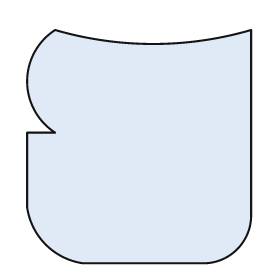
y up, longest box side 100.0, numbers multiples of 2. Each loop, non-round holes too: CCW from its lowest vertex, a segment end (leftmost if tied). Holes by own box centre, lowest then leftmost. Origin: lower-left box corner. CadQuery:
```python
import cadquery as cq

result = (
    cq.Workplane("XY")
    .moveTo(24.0, 0.0)
    .lineTo(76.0, 0.0)
    .threePointArc((90.0, 6.0), (96.0, 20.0))
    .lineTo(96.0, 100.0)
    .threePointArc((54.0, 94.0), (12.0, 100.0))
    .threePointArc((0.0, 78.0), (12.0, 56.0))
    .lineTo(0.0, 56.0)
    .lineTo(0.0, 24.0)
    .threePointArc((8.0, 8.0), (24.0, 0.0))
    .close()
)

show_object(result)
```